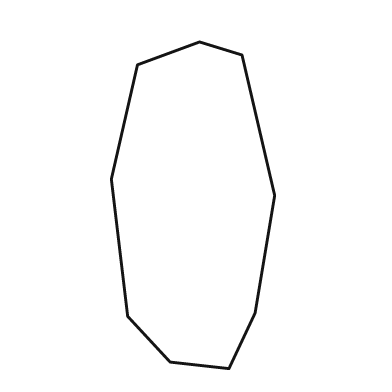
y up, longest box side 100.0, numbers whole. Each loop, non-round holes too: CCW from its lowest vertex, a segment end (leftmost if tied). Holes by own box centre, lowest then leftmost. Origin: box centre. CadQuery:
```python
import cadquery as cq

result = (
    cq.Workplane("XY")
    .moveTo(11.0, -50.0)
    .lineTo(19.0, -33.0)
    .lineTo(25.0, 3.0)
    .lineTo(15.0, 46.0)
    .lineTo(2.0, 50.0)
    .lineTo(-17.0, 43.0)
    .lineTo(-25.0, 8.0)
    .lineTo(-20.0, -34.0)
    .lineTo(-7.0, -48.0)
    .close()
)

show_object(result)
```